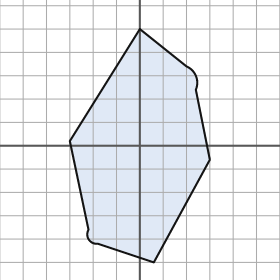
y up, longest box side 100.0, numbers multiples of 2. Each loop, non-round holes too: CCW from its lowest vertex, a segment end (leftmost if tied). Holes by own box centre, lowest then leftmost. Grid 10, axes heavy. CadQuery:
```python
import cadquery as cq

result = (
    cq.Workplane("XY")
    .moveTo(6.0, -50.0)
    .lineTo(30.0, -6.0)
    .lineTo(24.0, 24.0)
    .threePointArc((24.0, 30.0), (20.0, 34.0))
    .lineTo(0.0, 50.0)
    .lineTo(-30.0, 2.0)
    .lineTo(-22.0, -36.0)
    .threePointArc((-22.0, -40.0), (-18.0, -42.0))
    .close()
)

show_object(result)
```